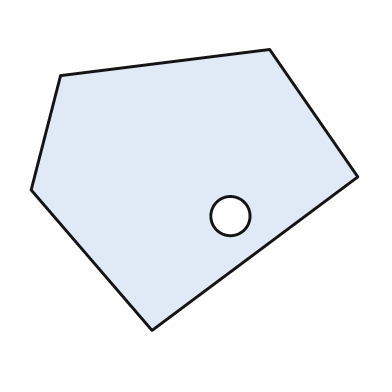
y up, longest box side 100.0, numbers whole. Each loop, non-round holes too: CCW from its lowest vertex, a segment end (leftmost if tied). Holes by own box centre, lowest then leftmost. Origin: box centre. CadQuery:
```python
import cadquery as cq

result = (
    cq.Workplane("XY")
    .moveTo(-13.0, -43.0)
    .lineTo(50.0, 4.0)
    .lineTo(23.0, 43.0)
    .lineTo(-41.0, 35.0)
    .lineTo(-50.0, 0.0)
    .close()
    .moveTo(11.0, -8.0)
    .circle(6.0)
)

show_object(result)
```